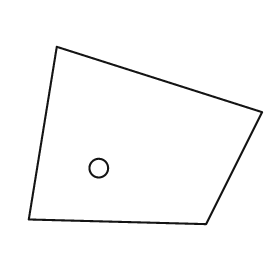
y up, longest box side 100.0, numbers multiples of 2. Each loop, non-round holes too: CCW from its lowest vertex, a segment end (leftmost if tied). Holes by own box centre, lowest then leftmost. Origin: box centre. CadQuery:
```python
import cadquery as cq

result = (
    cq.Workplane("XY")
    .moveTo(26.0, -38.0)
    .lineTo(50.0, 10.0)
    .lineTo(-38.0, 38.0)
    .lineTo(-50.0, -36.0)
    .close()
    .moveTo(-20.0, -14.0)
    .circle(4.0)
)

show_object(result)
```